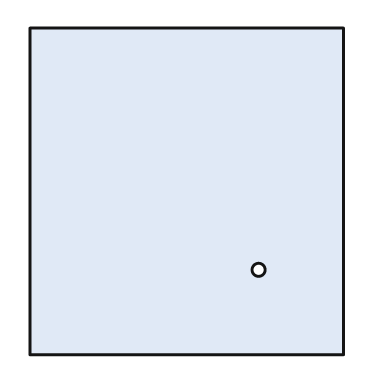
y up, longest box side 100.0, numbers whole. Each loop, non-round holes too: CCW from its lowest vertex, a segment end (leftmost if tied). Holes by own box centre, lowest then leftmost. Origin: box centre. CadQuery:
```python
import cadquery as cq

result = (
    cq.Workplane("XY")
    .moveTo(-48.0, -50.0)
    .lineTo(48.0, -50.0)
    .lineTo(48.0, 50.0)
    .lineTo(-48.0, 50.0)
    .close()
    .moveTo(22.0, -24.0)
    .circle(2.0)
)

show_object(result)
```